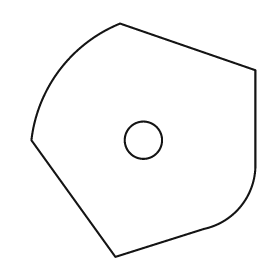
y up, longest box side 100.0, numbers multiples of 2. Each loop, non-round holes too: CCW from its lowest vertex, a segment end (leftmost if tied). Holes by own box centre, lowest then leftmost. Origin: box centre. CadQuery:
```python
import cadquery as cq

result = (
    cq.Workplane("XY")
    .moveTo(-12.0, -50.0)
    .lineTo(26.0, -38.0)
    .threePointArc((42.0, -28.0), (48.0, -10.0))
    .lineTo(48.0, 30.0)
    .lineTo(-10.0, 50.0)
    .threePointArc((-36.0, 30.0), (-48.0, 0.0))
    .close()
    .moveTo(0.0, 0.0)
    .circle(8.0)
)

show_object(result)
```